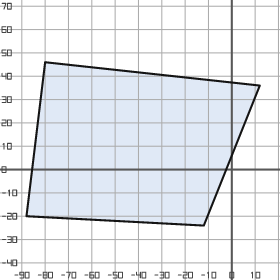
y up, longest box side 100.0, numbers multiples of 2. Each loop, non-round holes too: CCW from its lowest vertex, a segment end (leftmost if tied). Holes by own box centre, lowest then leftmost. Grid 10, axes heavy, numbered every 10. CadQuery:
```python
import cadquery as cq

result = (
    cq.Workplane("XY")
    .moveTo(-12.0, -24.0)
    .lineTo(12.0, 36.0)
    .lineTo(-80.0, 46.0)
    .lineTo(-88.0, -20.0)
    .close()
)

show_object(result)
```